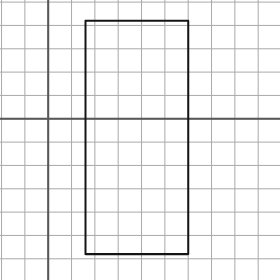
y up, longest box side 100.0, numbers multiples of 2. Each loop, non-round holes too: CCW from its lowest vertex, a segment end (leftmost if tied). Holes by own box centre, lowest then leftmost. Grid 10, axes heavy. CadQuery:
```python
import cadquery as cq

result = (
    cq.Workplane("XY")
    .moveTo(16.0, -58.0)
    .lineTo(60.0, -58.0)
    .lineTo(60.0, 42.0)
    .lineTo(16.0, 42.0)
    .close()
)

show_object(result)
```